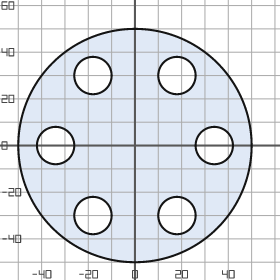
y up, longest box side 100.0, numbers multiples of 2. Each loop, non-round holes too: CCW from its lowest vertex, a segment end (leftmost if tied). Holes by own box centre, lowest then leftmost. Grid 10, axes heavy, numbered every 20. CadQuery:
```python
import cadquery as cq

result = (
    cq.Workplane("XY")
    .moveTo(0.0, 0.0)
    .circle(50.0)
    .moveTo(-18.0, -30.0)
    .circle(8.0)
    .moveTo(18.0, -30.0)
    .circle(8.0)
    .moveTo(-34.0, 0.0)
    .circle(8.0)
    .moveTo(34.0, 0.0)
    .circle(8.0)
    .moveTo(-18.0, 30.0)
    .circle(8.0)
    .moveTo(18.0, 30.0)
    .circle(8.0)
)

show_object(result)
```